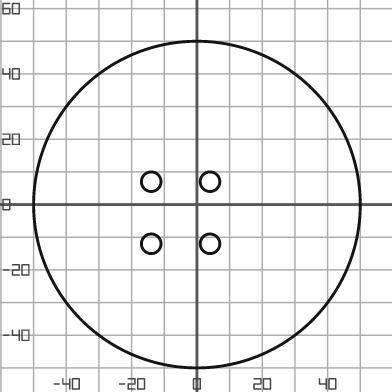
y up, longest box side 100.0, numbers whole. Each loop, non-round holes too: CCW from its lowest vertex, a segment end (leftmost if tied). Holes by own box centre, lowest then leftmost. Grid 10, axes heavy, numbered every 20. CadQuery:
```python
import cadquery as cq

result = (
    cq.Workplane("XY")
    .moveTo(0.0, 0.0)
    .circle(50.0)
    .moveTo(-14.0, -12.0)
    .circle(3.0)
    .moveTo(4.0, -12.0)
    .circle(3.0)
    .moveTo(-14.0, 7.0)
    .circle(3.0)
    .moveTo(4.0, 7.0)
    .circle(3.0)
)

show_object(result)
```